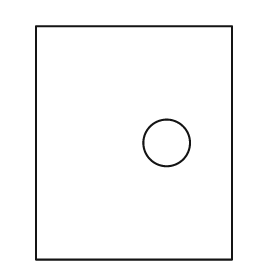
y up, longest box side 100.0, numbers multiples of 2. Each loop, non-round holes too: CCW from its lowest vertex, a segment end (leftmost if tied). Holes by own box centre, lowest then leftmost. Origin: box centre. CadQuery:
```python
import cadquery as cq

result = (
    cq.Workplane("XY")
    .moveTo(-42.0, -50.0)
    .lineTo(42.0, -50.0)
    .lineTo(42.0, 50.0)
    .lineTo(-42.0, 50.0)
    .close()
    .moveTo(14.0, 0.0)
    .circle(10.0)
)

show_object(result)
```